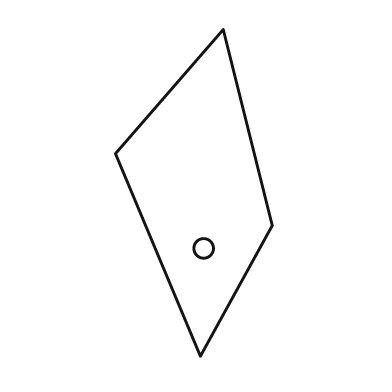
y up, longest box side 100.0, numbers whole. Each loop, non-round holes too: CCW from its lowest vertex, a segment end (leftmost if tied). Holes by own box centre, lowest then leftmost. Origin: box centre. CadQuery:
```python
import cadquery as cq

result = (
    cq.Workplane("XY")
    .moveTo(2.0, -50.0)
    .lineTo(24.0, -10.0)
    .lineTo(9.0, 50.0)
    .lineTo(-24.0, 12.0)
    .close()
    .moveTo(3.0, -17.0)
    .circle(3.0)
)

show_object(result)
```